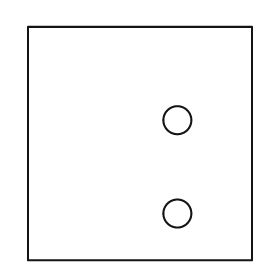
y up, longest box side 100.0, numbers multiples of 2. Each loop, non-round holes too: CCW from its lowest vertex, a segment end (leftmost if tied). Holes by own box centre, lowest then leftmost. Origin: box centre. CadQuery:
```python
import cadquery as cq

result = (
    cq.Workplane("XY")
    .moveTo(-48.0, -50.0)
    .lineTo(48.0, -50.0)
    .lineTo(48.0, 50.0)
    .lineTo(-48.0, 50.0)
    .close()
    .moveTo(16.0, -30.0)
    .circle(6.0)
    .moveTo(16.0, 10.0)
    .circle(6.0)
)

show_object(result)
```